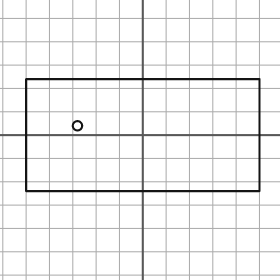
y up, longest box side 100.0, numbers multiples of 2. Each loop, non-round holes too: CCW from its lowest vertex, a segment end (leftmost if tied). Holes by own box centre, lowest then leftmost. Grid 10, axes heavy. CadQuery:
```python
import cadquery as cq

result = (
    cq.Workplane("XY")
    .moveTo(-50.0, -24.0)
    .lineTo(50.0, -24.0)
    .lineTo(50.0, 24.0)
    .lineTo(-50.0, 24.0)
    .close()
    .moveTo(-28.0, 4.0)
    .circle(2.0)
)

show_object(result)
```